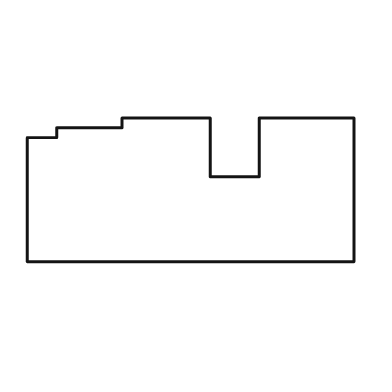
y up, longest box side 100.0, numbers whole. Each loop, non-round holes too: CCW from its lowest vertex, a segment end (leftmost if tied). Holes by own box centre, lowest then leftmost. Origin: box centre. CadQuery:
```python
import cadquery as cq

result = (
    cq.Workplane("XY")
    .moveTo(-50.0, -22.0)
    .lineTo(50.0, -22.0)
    .lineTo(50.0, 22.0)
    .lineTo(21.0, 22.0)
    .lineTo(21.0, 4.0)
    .lineTo(6.0, 4.0)
    .lineTo(6.0, 22.0)
    .lineTo(-21.0, 22.0)
    .lineTo(-21.0, 19.0)
    .lineTo(-41.0, 19.0)
    .lineTo(-41.0, 16.0)
    .lineTo(-50.0, 16.0)
    .close()
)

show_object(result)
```